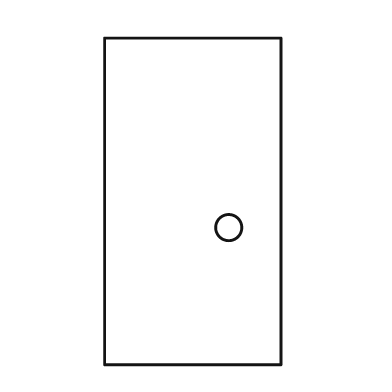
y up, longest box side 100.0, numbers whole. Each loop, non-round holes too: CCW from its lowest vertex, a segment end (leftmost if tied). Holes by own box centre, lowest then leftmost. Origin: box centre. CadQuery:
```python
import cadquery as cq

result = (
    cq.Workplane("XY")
    .moveTo(-27.0, -50.0)
    .lineTo(27.0, -50.0)
    .lineTo(27.0, 50.0)
    .lineTo(-27.0, 50.0)
    .close()
    .moveTo(11.0, -8.0)
    .circle(4.0)
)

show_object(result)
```